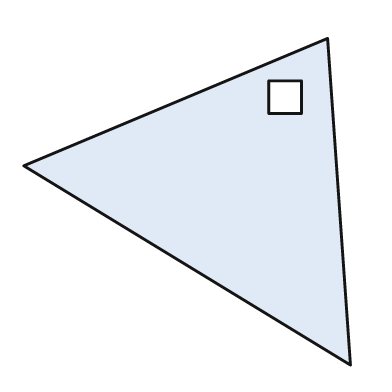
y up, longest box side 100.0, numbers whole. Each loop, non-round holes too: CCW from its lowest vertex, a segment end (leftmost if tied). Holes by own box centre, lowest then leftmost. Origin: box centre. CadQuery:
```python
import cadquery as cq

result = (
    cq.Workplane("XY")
    .moveTo(50.0, -50.0)
    .lineTo(43.0, 50.0)
    .lineTo(-50.0, 11.0)
    .close()
    .moveTo(25.0, 27.0)
    .lineTo(35.0, 27.0)
    .lineTo(35.0, 37.0)
    .lineTo(25.0, 37.0)
    .close()
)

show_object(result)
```